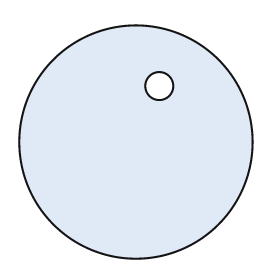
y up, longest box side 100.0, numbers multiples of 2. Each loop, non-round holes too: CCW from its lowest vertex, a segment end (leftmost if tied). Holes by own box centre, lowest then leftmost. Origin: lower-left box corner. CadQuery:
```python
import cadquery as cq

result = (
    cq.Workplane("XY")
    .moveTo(50.0, 50.0)
    .circle(50.0)
    .moveTo(60.0, 74.0)
    .circle(6.0)
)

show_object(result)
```